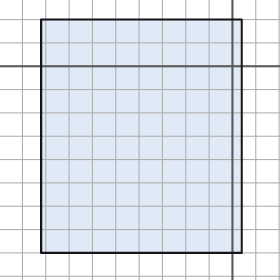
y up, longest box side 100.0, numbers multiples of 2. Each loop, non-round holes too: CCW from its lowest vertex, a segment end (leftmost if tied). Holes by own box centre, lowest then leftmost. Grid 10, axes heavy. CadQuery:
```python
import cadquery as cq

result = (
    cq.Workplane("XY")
    .moveTo(-82.0, -80.0)
    .lineTo(4.0, -80.0)
    .lineTo(4.0, 20.0)
    .lineTo(-82.0, 20.0)
    .close()
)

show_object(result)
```